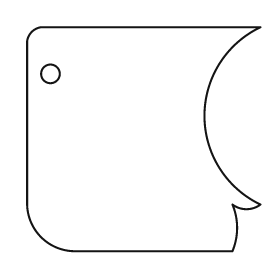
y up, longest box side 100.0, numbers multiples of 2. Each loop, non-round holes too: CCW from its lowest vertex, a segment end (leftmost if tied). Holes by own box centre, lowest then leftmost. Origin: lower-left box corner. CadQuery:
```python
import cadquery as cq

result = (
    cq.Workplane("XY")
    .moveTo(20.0, 0.0)
    .lineTo(88.0, 0.0)
    .threePointArc((90.0, 10.0), (88.0, 20.0))
    .threePointArc((94.0, 18.0), (100.0, 20.0))
    .threePointArc((76.0, 58.0), (100.0, 96.0))
    .lineTo(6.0, 96.0)
    .threePointArc((2.0, 94.0), (0.0, 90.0))
    .lineTo(0.0, 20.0)
    .threePointArc((6.0, 6.0), (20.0, 0.0))
    .close()
    .moveTo(10.0, 76.0)
    .circle(4.0)
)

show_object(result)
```